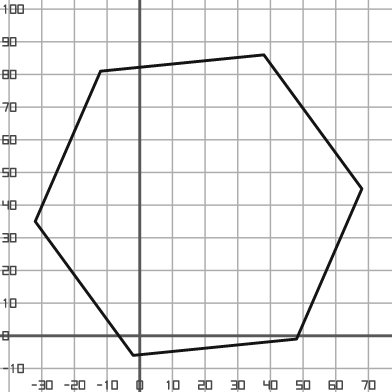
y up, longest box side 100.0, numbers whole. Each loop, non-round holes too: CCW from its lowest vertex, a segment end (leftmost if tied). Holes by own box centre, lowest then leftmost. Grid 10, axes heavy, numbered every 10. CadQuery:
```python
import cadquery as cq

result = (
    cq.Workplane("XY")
    .moveTo(-2.0, -6.0)
    .lineTo(48.0, -1.0)
    .lineTo(68.0, 45.0)
    .lineTo(38.0, 86.0)
    .lineTo(-12.0, 81.0)
    .lineTo(-32.0, 35.0)
    .close()
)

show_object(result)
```